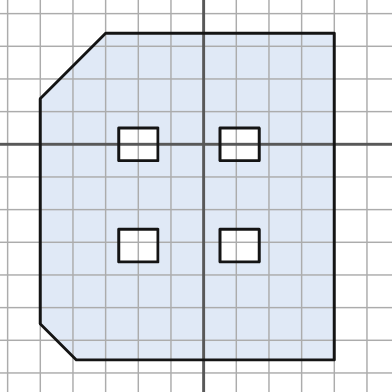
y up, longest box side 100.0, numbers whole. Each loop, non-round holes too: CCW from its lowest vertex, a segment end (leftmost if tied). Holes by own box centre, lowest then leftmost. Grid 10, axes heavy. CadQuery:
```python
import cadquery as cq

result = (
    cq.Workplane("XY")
    .moveTo(-39.0, -66.0)
    .lineTo(40.0, -66.0)
    .lineTo(40.0, 34.0)
    .lineTo(-30.0, 34.0)
    .lineTo(-50.0, 14.0)
    .lineTo(-50.0, -55.0)
    .close()
    .moveTo(-26.0, -36.0)
    .lineTo(-14.0, -36.0)
    .lineTo(-14.0, -26.0)
    .lineTo(-26.0, -26.0)
    .close()
    .moveTo(5.0, -36.0)
    .lineTo(17.0, -36.0)
    .lineTo(17.0, -26.0)
    .lineTo(5.0, -26.0)
    .close()
    .moveTo(-26.0, -5.0)
    .lineTo(-14.0, -5.0)
    .lineTo(-14.0, 5.0)
    .lineTo(-26.0, 5.0)
    .close()
    .moveTo(5.0, -5.0)
    .lineTo(17.0, -5.0)
    .lineTo(17.0, 5.0)
    .lineTo(5.0, 5.0)
    .close()
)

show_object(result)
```